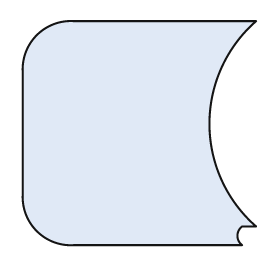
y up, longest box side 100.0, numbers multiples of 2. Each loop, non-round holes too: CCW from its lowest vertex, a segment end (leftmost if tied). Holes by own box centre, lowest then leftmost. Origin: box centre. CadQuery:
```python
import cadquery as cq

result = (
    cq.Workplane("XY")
    .moveTo(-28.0, -48.0)
    .lineTo(44.0, -48.0)
    .threePointArc((42.0, -44.0), (44.0, -40.0))
    .lineTo(50.0, -40.0)
    .threePointArc((30.0, 4.0), (50.0, 48.0))
    .lineTo(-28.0, 48.0)
    .threePointArc((-44.0, 42.0), (-50.0, 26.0))
    .lineTo(-50.0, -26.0)
    .threePointArc((-44.0, -42.0), (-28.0, -48.0))
    .close()
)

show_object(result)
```